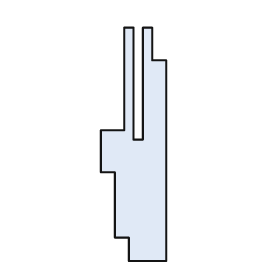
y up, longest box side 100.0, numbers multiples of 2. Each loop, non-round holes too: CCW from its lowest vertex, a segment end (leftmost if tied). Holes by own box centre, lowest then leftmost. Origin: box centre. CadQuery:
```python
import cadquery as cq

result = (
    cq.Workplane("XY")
    .moveTo(-2.0, -50.0)
    .lineTo(14.0, -50.0)
    .lineTo(14.0, 36.0)
    .lineTo(8.0, 36.0)
    .lineTo(8.0, 50.0)
    .lineTo(4.0, 50.0)
    .lineTo(4.0, 2.0)
    .lineTo(0.0, 2.0)
    .lineTo(0.0, 50.0)
    .lineTo(-4.0, 50.0)
    .lineTo(-4.0, 6.0)
    .lineTo(-14.0, 6.0)
    .lineTo(-14.0, -12.0)
    .lineTo(-8.0, -12.0)
    .lineTo(-8.0, -40.0)
    .lineTo(-2.0, -40.0)
    .close()
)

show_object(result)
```